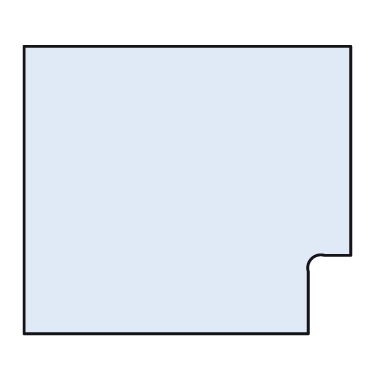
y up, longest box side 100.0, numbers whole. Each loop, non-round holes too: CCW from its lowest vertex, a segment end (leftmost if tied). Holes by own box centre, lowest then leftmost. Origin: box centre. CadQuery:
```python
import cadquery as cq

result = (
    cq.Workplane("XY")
    .moveTo(-50.0, -44.0)
    .lineTo(37.0, -44.0)
    .lineTo(37.0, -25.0)
    .threePointArc((38.0, -21.0), (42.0, -20.0))
    .lineTo(50.0, -20.0)
    .lineTo(50.0, 44.0)
    .lineTo(-50.0, 44.0)
    .close()
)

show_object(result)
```